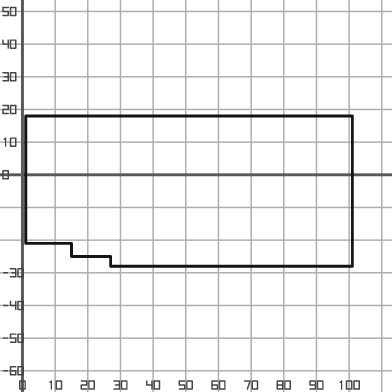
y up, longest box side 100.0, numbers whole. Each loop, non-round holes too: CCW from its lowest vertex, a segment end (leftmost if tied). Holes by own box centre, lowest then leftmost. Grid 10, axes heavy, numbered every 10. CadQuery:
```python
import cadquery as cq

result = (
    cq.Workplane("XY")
    .moveTo(27.0, -28.0)
    .lineTo(101.0, -28.0)
    .lineTo(101.0, 18.0)
    .lineTo(1.0, 18.0)
    .lineTo(1.0, -21.0)
    .lineTo(15.0, -21.0)
    .lineTo(15.0, -25.0)
    .lineTo(27.0, -25.0)
    .close()
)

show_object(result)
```